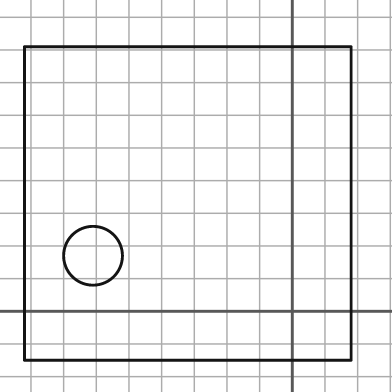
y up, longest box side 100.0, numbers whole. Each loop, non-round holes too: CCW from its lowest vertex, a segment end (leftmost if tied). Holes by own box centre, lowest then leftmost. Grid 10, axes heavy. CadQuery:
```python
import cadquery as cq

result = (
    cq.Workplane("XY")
    .moveTo(-82.0, -15.0)
    .lineTo(18.0, -15.0)
    .lineTo(18.0, 81.0)
    .lineTo(-82.0, 81.0)
    .close()
    .moveTo(-61.0, 17.0)
    .circle(9.0)
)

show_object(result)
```